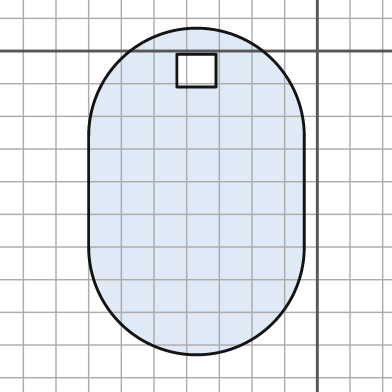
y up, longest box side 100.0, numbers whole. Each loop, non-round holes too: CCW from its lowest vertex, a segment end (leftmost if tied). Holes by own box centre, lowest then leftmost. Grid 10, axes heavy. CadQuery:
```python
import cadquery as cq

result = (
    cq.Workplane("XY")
    .moveTo(-70.0, -60.0)
    .threePointArc((-37.0, -93.0), (-4.0, -60.0))
    .lineTo(-4.0, -26.0)
    .threePointArc((-37.0, 7.0), (-70.0, -26.0))
    .close()
    .moveTo(-43.0, -11.0)
    .lineTo(-31.0, -11.0)
    .lineTo(-31.0, -1.0)
    .lineTo(-43.0, -1.0)
    .close()
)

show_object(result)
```